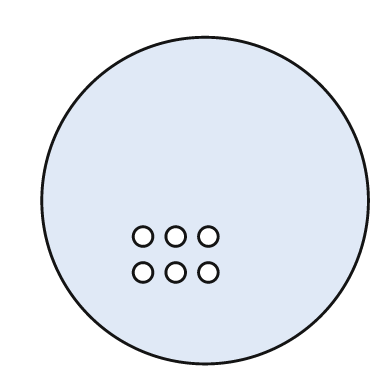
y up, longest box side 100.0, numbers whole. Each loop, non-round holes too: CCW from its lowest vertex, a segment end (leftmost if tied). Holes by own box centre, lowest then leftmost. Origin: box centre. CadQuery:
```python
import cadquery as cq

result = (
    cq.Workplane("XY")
    .moveTo(0.0, 0.0)
    .circle(50.0)
    .moveTo(-19.0, -22.0)
    .circle(3.0)
    .moveTo(-9.0, -22.0)
    .circle(3.0)
    .moveTo(1.0, -22.0)
    .circle(3.0)
    .moveTo(-19.0, -11.0)
    .circle(3.0)
    .moveTo(-9.0, -11.0)
    .circle(3.0)
    .moveTo(1.0, -11.0)
    .circle(3.0)
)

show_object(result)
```